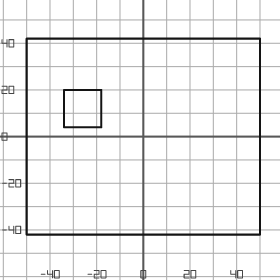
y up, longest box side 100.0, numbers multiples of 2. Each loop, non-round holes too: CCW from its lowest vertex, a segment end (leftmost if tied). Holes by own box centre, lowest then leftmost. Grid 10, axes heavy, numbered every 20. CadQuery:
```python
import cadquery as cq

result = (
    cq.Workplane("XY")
    .moveTo(-50.0, -42.0)
    .lineTo(50.0, -42.0)
    .lineTo(50.0, 42.0)
    .lineTo(-50.0, 42.0)
    .close()
    .moveTo(-34.0, 4.0)
    .lineTo(-18.0, 4.0)
    .lineTo(-18.0, 20.0)
    .lineTo(-34.0, 20.0)
    .close()
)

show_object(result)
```